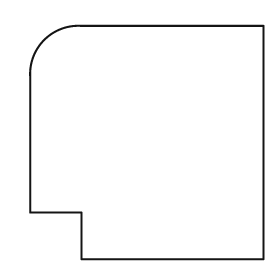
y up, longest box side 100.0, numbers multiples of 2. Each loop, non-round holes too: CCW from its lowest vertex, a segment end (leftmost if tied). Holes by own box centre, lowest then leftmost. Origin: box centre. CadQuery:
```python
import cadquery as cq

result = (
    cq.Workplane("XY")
    .moveTo(-28.0, -50.0)
    .lineTo(50.0, -50.0)
    .lineTo(50.0, 50.0)
    .lineTo(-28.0, 50.0)
    .threePointArc((-44.0, 44.0), (-50.0, 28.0))
    .lineTo(-50.0, -30.0)
    .lineTo(-28.0, -30.0)
    .close()
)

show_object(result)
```